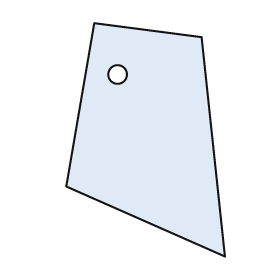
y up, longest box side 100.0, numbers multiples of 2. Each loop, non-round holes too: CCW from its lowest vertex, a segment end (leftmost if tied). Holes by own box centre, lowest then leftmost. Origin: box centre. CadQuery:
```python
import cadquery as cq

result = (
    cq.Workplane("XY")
    .moveTo(34.0, -50.0)
    .lineTo(24.0, 44.0)
    .lineTo(-22.0, 50.0)
    .lineTo(-34.0, -20.0)
    .close()
    .moveTo(-12.0, 28.0)
    .circle(4.0)
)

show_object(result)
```